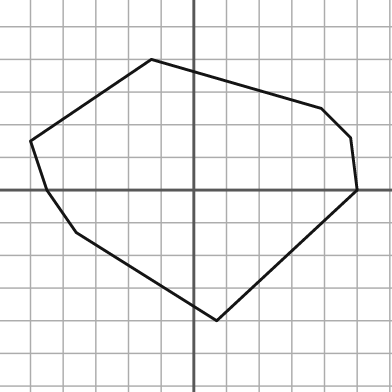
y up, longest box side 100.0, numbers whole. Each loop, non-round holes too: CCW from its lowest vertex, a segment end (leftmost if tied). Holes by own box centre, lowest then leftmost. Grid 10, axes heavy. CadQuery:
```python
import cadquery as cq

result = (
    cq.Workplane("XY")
    .moveTo(7.0, -40.0)
    .lineTo(50.0, 0.0)
    .lineTo(48.0, 16.0)
    .lineTo(39.0, 25.0)
    .lineTo(-13.0, 40.0)
    .lineTo(-50.0, 15.0)
    .lineTo(-45.0, 0.0)
    .lineTo(-36.0, -13.0)
    .close()
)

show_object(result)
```